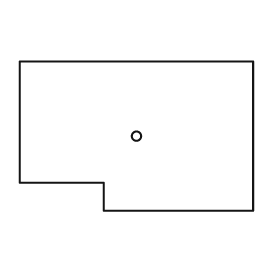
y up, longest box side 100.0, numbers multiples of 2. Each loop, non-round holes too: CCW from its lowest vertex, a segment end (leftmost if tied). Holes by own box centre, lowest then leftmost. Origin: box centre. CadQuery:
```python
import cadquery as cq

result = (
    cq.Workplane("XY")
    .moveTo(-14.0, -32.0)
    .lineTo(50.0, -32.0)
    .lineTo(50.0, 32.0)
    .lineTo(-50.0, 32.0)
    .lineTo(-50.0, -20.0)
    .lineTo(-14.0, -20.0)
    .close()
    .moveTo(0.0, 0.0)
    .circle(2.0)
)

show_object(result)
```